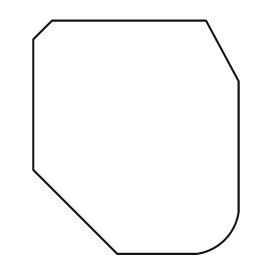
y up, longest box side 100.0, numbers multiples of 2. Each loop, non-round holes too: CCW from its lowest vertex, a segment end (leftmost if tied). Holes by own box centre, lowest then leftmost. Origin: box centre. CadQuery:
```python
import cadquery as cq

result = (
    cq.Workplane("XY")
    .moveTo(-8.0, -50.0)
    .lineTo(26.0, -50.0)
    .threePointArc((38.0, -44.0), (44.0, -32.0))
    .lineTo(44.0, 24.0)
    .lineTo(30.0, 50.0)
    .lineTo(-36.0, 50.0)
    .lineTo(-44.0, 42.0)
    .lineTo(-44.0, -14.0)
    .close()
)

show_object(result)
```